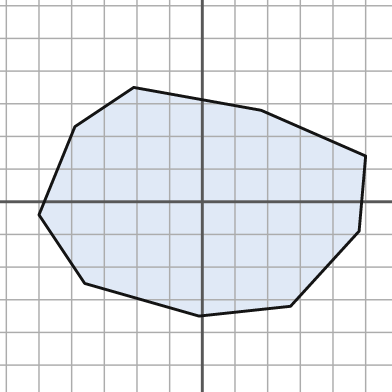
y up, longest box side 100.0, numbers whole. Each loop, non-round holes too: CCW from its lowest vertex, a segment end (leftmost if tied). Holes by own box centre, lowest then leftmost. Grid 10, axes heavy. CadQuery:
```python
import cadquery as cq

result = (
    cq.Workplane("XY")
    .moveTo(-1.0, -35.0)
    .lineTo(27.0, -32.0)
    .lineTo(48.0, -9.0)
    .lineTo(50.0, 14.0)
    .lineTo(18.0, 28.0)
    .lineTo(-21.0, 35.0)
    .lineTo(-39.0, 23.0)
    .lineTo(-50.0, -4.0)
    .lineTo(-36.0, -25.0)
    .close()
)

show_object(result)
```